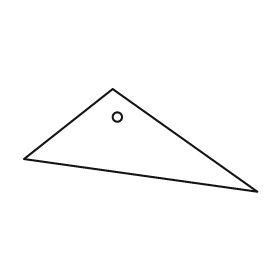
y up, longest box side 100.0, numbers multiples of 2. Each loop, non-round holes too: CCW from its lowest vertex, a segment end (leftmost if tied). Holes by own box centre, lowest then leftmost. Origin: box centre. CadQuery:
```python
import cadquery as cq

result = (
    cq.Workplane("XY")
    .moveTo(50.0, -22.0)
    .lineTo(-12.0, 22.0)
    .lineTo(-50.0, -8.0)
    .close()
    .moveTo(-10.0, 10.0)
    .circle(2.0)
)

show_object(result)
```